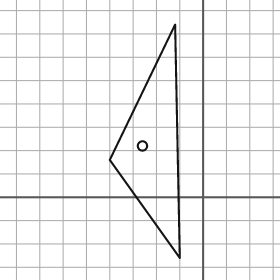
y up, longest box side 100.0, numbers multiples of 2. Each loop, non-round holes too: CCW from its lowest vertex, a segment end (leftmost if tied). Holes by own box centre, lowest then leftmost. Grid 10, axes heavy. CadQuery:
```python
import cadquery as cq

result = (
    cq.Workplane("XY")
    .moveTo(-10.0, -26.0)
    .lineTo(-12.0, 74.0)
    .lineTo(-40.0, 16.0)
    .close()
    .moveTo(-26.0, 22.0)
    .circle(2.0)
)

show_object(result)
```